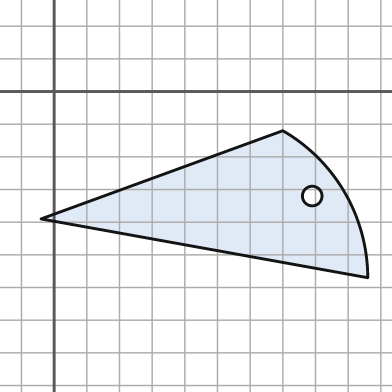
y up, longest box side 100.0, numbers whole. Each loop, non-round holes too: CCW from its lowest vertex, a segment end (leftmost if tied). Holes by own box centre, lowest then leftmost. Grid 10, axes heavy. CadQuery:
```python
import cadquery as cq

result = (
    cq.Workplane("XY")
    .moveTo(96.0, -57.0)
    .threePointArc((89.0, -31.0), (70.0, -12.0))
    .lineTo(-4.0, -39.0)
    .close()
    .moveTo(79.0, -32.0)
    .circle(3.0)
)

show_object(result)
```